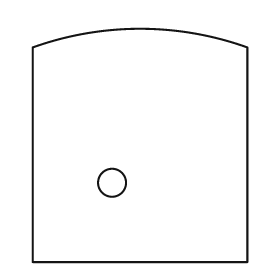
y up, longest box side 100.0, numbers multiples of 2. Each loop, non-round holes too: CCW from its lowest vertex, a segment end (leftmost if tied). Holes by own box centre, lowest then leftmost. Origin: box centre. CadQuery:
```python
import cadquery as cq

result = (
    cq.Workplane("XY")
    .moveTo(-46.0, -50.0)
    .lineTo(46.0, -50.0)
    .lineTo(46.0, 42.0)
    .threePointArc((0.0, 50.0), (-46.0, 42.0))
    .close()
    .moveTo(-12.0, -16.0)
    .circle(6.0)
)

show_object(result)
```